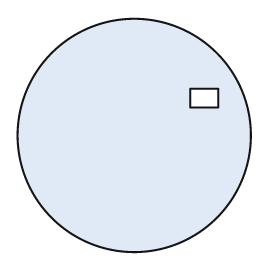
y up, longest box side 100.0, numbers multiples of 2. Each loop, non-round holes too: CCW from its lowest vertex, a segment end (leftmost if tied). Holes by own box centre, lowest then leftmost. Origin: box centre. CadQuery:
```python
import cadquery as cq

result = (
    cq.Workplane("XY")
    .moveTo(0.0, 0.0)
    .circle(50.0)
    .moveTo(24.0, 12.0)
    .lineTo(36.0, 12.0)
    .lineTo(36.0, 20.0)
    .lineTo(24.0, 20.0)
    .close()
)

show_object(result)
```